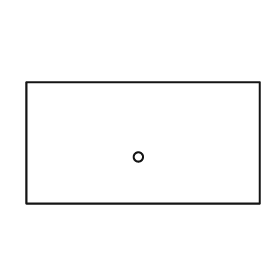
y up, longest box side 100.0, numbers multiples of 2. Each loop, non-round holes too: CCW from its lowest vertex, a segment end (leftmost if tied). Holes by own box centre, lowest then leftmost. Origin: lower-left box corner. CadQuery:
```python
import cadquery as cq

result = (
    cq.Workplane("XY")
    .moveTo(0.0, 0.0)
    .lineTo(100.0, 0.0)
    .lineTo(100.0, 52.0)
    .lineTo(0.0, 52.0)
    .close()
    .moveTo(48.0, 20.0)
    .circle(2.0)
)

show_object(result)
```